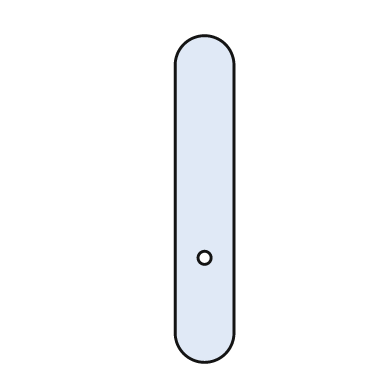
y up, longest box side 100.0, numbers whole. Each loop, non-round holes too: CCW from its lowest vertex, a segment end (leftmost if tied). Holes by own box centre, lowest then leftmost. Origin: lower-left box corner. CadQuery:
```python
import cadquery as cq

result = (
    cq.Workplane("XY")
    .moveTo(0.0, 9.0)
    .threePointArc((9.0, 0.0), (18.0, 9.0))
    .lineTo(18.0, 91.0)
    .threePointArc((9.0, 100.0), (0.0, 91.0))
    .close()
    .moveTo(9.0, 32.0)
    .circle(2.0)
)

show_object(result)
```